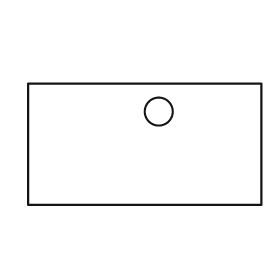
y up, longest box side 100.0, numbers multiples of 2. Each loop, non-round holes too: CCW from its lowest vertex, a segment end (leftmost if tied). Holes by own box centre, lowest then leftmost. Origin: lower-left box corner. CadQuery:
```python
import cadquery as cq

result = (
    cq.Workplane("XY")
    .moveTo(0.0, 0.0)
    .lineTo(100.0, 0.0)
    .lineTo(100.0, 52.0)
    .lineTo(0.0, 52.0)
    .close()
    .moveTo(56.0, 40.0)
    .circle(6.0)
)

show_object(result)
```